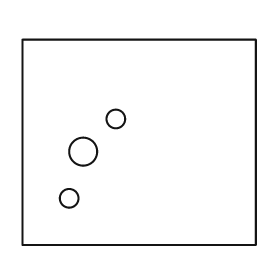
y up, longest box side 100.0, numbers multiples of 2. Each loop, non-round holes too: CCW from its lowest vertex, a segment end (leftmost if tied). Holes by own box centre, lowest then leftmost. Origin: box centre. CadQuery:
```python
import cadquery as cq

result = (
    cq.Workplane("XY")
    .moveTo(-50.0, -44.0)
    .lineTo(50.0, -44.0)
    .lineTo(50.0, 44.0)
    .lineTo(-50.0, 44.0)
    .close()
    .moveTo(-30.0, -24.0)
    .circle(4.0)
    .moveTo(-24.0, -4.0)
    .circle(6.0)
    .moveTo(-10.0, 10.0)
    .circle(4.0)
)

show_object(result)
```